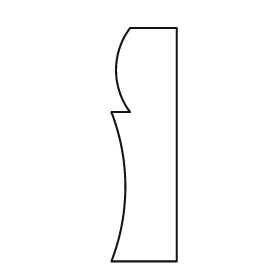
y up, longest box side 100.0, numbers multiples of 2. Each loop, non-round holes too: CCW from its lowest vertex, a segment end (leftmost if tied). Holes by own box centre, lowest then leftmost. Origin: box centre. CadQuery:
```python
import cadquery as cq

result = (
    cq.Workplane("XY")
    .moveTo(-14.0, -50.0)
    .lineTo(14.0, -50.0)
    .lineTo(14.0, 50.0)
    .lineTo(-6.0, 50.0)
    .threePointArc((-12.0, 32.0), (-6.0, 14.0))
    .lineTo(-14.0, 14.0)
    .threePointArc((-8.0, -18.0), (-14.0, -50.0))
    .close()
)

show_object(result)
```